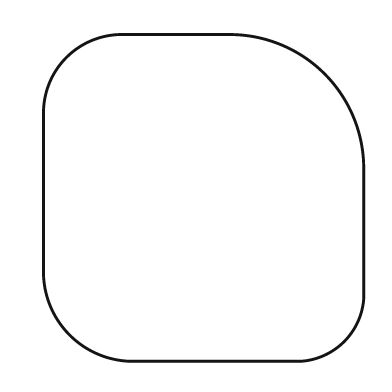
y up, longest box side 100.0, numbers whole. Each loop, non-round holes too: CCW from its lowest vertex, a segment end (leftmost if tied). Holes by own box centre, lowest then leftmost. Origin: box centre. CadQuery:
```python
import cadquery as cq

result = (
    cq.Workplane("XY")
    .moveTo(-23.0, -50.0)
    .lineTo(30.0, -50.0)
    .threePointArc((43.0, -44.0), (49.0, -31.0))
    .lineTo(49.0, 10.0)
    .threePointArc((37.0, 38.0), (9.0, 50.0))
    .lineTo(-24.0, 50.0)
    .threePointArc((-42.0, 43.0), (-49.0, 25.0))
    .lineTo(-49.0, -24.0)
    .threePointArc((-41.0, -42.0), (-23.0, -50.0))
    .close()
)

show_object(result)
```